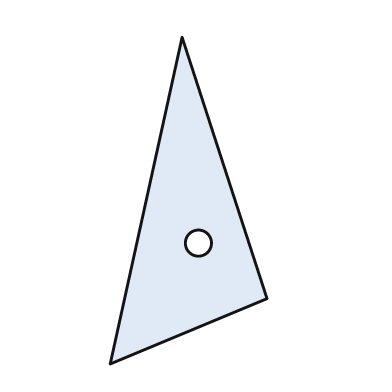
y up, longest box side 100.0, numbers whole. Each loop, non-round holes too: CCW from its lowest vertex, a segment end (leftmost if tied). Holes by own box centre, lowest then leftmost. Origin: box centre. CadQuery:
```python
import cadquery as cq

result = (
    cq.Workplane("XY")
    .moveTo(-24.0, -50.0)
    .lineTo(24.0, -30.0)
    .lineTo(-2.0, 50.0)
    .close()
    .moveTo(3.0, -13.0)
    .circle(4.0)
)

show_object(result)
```